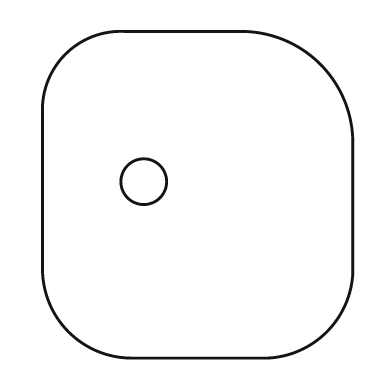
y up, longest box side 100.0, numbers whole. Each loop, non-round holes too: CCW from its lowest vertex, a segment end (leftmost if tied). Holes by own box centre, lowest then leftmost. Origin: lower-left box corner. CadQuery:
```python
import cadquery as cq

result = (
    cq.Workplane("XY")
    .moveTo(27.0, 0.0)
    .lineTo(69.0, 0.0)
    .threePointArc((87.0, 8.0), (95.0, 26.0))
    .lineTo(95.0, 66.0)
    .threePointArc((85.0, 90.0), (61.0, 100.0))
    .lineTo(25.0, 100.0)
    .threePointArc((7.0, 93.0), (0.0, 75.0))
    .lineTo(0.0, 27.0)
    .threePointArc((8.0, 8.0), (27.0, 0.0))
    .close()
    .moveTo(31.0, 54.0)
    .circle(7.0)
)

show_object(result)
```